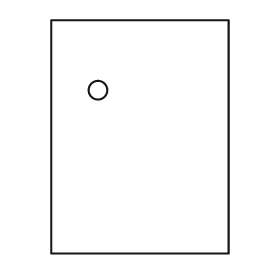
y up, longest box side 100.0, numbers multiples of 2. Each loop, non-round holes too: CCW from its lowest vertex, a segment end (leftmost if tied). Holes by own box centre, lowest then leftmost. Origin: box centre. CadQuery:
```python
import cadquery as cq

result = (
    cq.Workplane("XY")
    .moveTo(-38.0, -50.0)
    .lineTo(38.0, -50.0)
    .lineTo(38.0, 50.0)
    .lineTo(-38.0, 50.0)
    .close()
    .moveTo(-18.0, 20.0)
    .circle(4.0)
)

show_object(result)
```